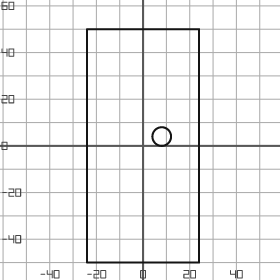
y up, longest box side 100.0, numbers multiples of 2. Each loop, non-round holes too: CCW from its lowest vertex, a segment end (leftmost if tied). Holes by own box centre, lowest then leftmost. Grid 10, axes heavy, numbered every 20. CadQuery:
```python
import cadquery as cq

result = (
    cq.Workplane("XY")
    .moveTo(-24.0, -50.0)
    .lineTo(24.0, -50.0)
    .lineTo(24.0, 50.0)
    .lineTo(-24.0, 50.0)
    .close()
    .moveTo(8.0, 4.0)
    .circle(4.0)
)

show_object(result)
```